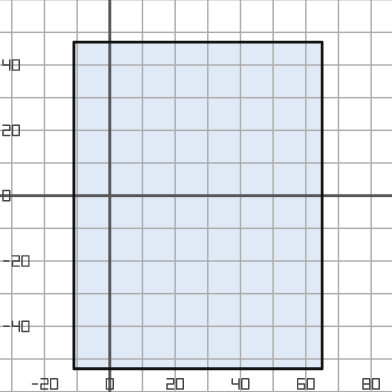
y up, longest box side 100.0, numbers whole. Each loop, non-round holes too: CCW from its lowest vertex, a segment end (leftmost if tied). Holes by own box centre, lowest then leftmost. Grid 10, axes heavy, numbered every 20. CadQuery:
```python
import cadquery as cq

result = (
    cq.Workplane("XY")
    .moveTo(-11.0, -53.0)
    .lineTo(65.0, -53.0)
    .lineTo(65.0, 47.0)
    .lineTo(-11.0, 47.0)
    .close()
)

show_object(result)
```